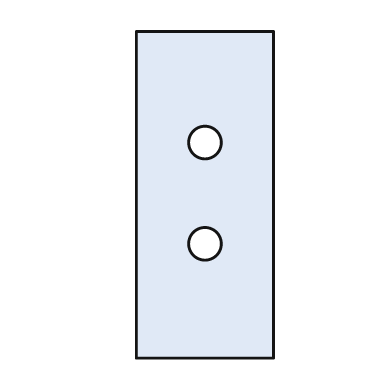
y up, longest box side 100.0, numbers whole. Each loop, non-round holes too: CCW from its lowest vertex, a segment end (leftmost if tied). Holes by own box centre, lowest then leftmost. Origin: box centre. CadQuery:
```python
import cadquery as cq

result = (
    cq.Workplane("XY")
    .moveTo(-21.0, -50.0)
    .lineTo(21.0, -50.0)
    .lineTo(21.0, 50.0)
    .lineTo(-21.0, 50.0)
    .close()
    .moveTo(0.0, -15.0)
    .circle(5.0)
    .moveTo(0.0, 16.0)
    .circle(5.0)
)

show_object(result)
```